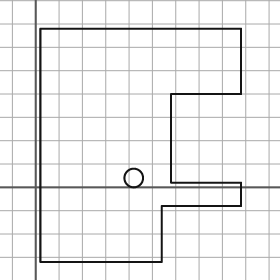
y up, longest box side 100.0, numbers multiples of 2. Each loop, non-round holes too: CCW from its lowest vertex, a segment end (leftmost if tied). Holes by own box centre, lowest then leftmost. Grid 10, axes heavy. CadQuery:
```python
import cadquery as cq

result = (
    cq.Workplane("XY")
    .moveTo(2.0, -32.0)
    .lineTo(54.0, -32.0)
    .lineTo(54.0, -8.0)
    .lineTo(88.0, -8.0)
    .lineTo(88.0, 2.0)
    .lineTo(58.0, 2.0)
    .lineTo(58.0, 40.0)
    .lineTo(88.0, 40.0)
    .lineTo(88.0, 68.0)
    .lineTo(2.0, 68.0)
    .close()
    .moveTo(42.0, 4.0)
    .circle(4.0)
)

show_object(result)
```